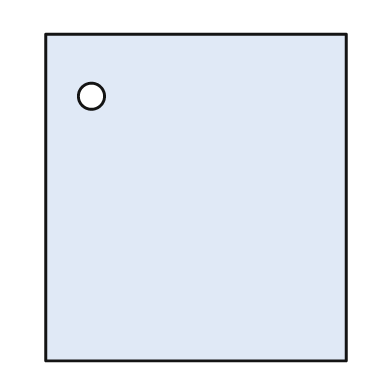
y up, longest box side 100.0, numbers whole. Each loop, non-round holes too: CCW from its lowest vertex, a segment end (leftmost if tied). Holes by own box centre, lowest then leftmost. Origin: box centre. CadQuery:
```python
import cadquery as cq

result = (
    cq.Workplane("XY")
    .moveTo(-46.0, -50.0)
    .lineTo(46.0, -50.0)
    .lineTo(46.0, 50.0)
    .lineTo(-46.0, 50.0)
    .close()
    .moveTo(-32.0, 31.0)
    .circle(4.0)
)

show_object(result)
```